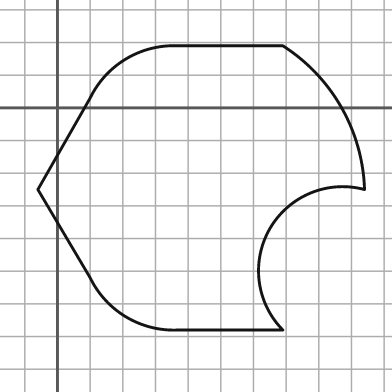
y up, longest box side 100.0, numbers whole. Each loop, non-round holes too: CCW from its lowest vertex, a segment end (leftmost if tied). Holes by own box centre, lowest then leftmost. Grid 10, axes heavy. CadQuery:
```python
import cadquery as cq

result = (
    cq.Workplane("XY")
    .moveTo(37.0, -68.0)
    .lineTo(69.0, -68.0)
    .threePointArc((65.0, -37.0), (94.0, -25.0))
    .threePointArc((87.0, 0.0), (69.0, 19.0))
    .lineTo(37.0, 19.0)
    .threePointArc((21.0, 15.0), (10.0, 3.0))
    .lineTo(-6.0, -25.0)
    .lineTo(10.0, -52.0)
    .threePointArc((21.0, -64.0), (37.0, -68.0))
    .close()
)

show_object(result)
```